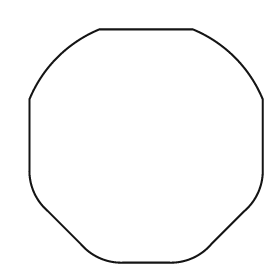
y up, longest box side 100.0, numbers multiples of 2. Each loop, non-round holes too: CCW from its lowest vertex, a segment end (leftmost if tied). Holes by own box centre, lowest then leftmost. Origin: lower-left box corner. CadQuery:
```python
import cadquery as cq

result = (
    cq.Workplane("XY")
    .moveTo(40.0, 0.0)
    .lineTo(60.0, 0.0)
    .threePointArc((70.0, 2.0), (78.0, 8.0))
    .lineTo(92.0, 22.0)
    .threePointArc((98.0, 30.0), (100.0, 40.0))
    .lineTo(100.0, 70.0)
    .threePointArc((88.0, 88.0), (70.0, 100.0))
    .lineTo(30.0, 100.0)
    .threePointArc((12.0, 88.0), (0.0, 70.0))
    .lineTo(0.0, 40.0)
    .threePointArc((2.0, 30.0), (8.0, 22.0))
    .lineTo(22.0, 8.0)
    .threePointArc((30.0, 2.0), (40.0, 0.0))
    .close()
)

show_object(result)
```